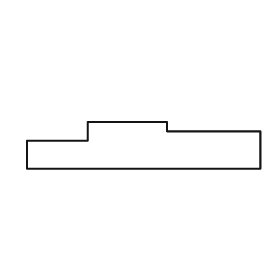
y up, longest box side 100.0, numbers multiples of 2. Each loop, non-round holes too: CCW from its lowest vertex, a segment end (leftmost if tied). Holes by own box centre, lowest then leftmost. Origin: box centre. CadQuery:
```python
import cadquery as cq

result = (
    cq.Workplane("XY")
    .moveTo(-50.0, -10.0)
    .lineTo(50.0, -10.0)
    .lineTo(50.0, 6.0)
    .lineTo(10.0, 6.0)
    .lineTo(10.0, 10.0)
    .lineTo(-24.0, 10.0)
    .lineTo(-24.0, 2.0)
    .lineTo(-50.0, 2.0)
    .close()
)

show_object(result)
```